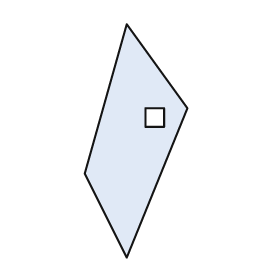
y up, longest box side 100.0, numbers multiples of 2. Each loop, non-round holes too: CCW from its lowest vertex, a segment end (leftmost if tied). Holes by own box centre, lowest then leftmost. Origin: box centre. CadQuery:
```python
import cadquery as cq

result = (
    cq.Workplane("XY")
    .moveTo(-4.0, -50.0)
    .lineTo(22.0, 14.0)
    .lineTo(-4.0, 50.0)
    .lineTo(-22.0, -14.0)
    .close()
    .moveTo(4.0, 6.0)
    .lineTo(12.0, 6.0)
    .lineTo(12.0, 14.0)
    .lineTo(4.0, 14.0)
    .close()
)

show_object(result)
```